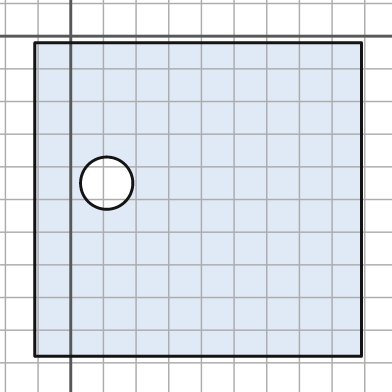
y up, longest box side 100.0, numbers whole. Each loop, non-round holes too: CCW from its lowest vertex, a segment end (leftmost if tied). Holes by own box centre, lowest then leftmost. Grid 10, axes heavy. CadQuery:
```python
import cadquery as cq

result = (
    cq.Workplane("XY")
    .moveTo(-11.0, -98.0)
    .lineTo(89.0, -98.0)
    .lineTo(89.0, -2.0)
    .lineTo(-11.0, -2.0)
    .close()
    .moveTo(11.0, -45.0)
    .circle(8.0)
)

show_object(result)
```